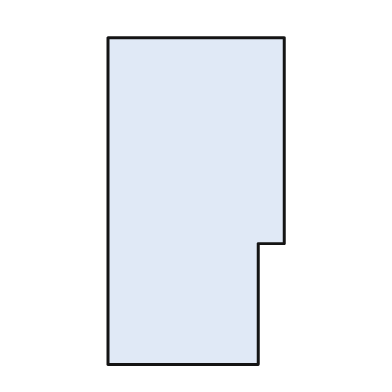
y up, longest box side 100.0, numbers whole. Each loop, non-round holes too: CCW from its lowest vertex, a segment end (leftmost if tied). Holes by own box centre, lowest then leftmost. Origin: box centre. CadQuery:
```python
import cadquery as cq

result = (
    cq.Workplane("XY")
    .moveTo(-27.0, -50.0)
    .lineTo(19.0, -50.0)
    .lineTo(19.0, -13.0)
    .lineTo(27.0, -13.0)
    .lineTo(27.0, 50.0)
    .lineTo(-27.0, 50.0)
    .close()
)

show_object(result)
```